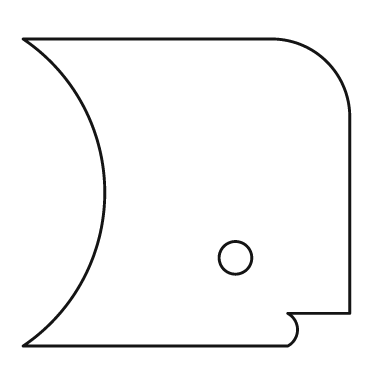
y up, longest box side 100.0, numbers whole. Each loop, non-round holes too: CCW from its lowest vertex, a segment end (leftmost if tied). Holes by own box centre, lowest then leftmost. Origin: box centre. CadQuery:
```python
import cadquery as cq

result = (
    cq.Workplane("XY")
    .moveTo(-50.0, -47.0)
    .lineTo(31.0, -47.0)
    .threePointArc((34.0, -42.0), (31.0, -37.0))
    .lineTo(50.0, -37.0)
    .lineTo(50.0, 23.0)
    .threePointArc((43.0, 40.0), (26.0, 47.0))
    .lineTo(-50.0, 47.0)
    .threePointArc((-25.0, 0.0), (-50.0, -47.0))
    .close()
    .moveTo(15.0, -20.0)
    .circle(5.0)
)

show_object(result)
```